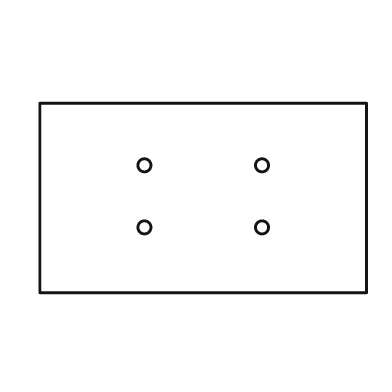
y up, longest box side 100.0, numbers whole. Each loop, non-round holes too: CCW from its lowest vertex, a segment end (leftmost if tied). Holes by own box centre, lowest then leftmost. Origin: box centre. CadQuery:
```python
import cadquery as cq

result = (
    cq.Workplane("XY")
    .moveTo(-50.0, -29.0)
    .lineTo(50.0, -29.0)
    .lineTo(50.0, 29.0)
    .lineTo(-50.0, 29.0)
    .close()
    .moveTo(-18.0, -9.0)
    .circle(2.0)
    .moveTo(18.0, -9.0)
    .circle(2.0)
    .moveTo(-18.0, 10.0)
    .circle(2.0)
    .moveTo(18.0, 10.0)
    .circle(2.0)
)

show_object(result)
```